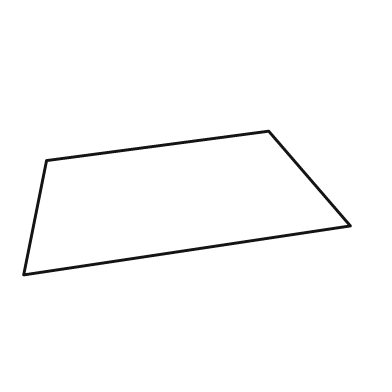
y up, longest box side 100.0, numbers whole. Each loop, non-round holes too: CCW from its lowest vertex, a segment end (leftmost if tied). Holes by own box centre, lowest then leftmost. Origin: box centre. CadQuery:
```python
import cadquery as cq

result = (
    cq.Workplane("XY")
    .moveTo(-50.0, -22.0)
    .lineTo(50.0, -7.0)
    .lineTo(25.0, 22.0)
    .lineTo(-43.0, 13.0)
    .close()
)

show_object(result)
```